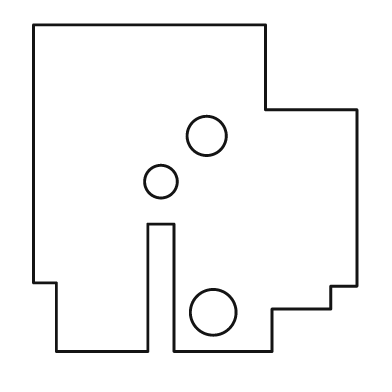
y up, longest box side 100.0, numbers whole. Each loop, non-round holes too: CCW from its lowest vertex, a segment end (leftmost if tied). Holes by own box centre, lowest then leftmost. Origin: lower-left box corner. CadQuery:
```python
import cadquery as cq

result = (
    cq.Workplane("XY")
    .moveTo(7.0, 0.0)
    .lineTo(35.0, 0.0)
    .lineTo(35.0, 39.0)
    .lineTo(43.0, 39.0)
    .lineTo(43.0, 0.0)
    .lineTo(73.0, 0.0)
    .lineTo(73.0, 13.0)
    .lineTo(91.0, 13.0)
    .lineTo(91.0, 20.0)
    .lineTo(99.0, 20.0)
    .lineTo(99.0, 74.0)
    .lineTo(71.0, 74.0)
    .lineTo(71.0, 100.0)
    .lineTo(0.0, 100.0)
    .lineTo(0.0, 21.0)
    .lineTo(7.0, 21.0)
    .close()
    .moveTo(55.0, 12.0)
    .circle(7.0)
    .moveTo(39.0, 52.0)
    .circle(5.0)
    .moveTo(53.0, 66.0)
    .circle(6.0)
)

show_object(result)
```